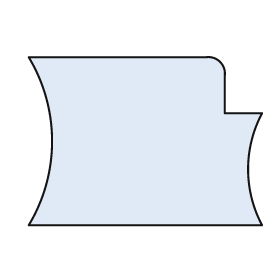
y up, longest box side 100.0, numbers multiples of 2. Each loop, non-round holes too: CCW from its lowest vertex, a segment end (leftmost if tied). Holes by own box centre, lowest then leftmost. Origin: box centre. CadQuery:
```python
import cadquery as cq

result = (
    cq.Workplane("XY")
    .moveTo(-50.0, -36.0)
    .lineTo(50.0, -36.0)
    .threePointArc((44.0, -12.0), (50.0, 12.0))
    .lineTo(34.0, 12.0)
    .lineTo(34.0, 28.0)
    .threePointArc((32.0, 34.0), (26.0, 36.0))
    .lineTo(-50.0, 36.0)
    .threePointArc((-40.0, 0.0), (-50.0, -36.0))
    .close()
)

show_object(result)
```